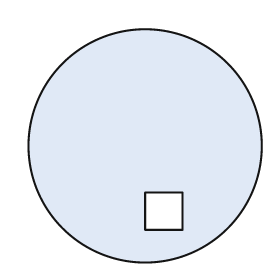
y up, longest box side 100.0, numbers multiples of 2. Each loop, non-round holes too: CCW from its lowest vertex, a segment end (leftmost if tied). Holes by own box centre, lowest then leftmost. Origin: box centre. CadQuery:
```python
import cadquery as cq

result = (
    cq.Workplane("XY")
    .moveTo(0.0, 0.0)
    .circle(50.0)
    .moveTo(0.0, -36.0)
    .lineTo(16.0, -36.0)
    .lineTo(16.0, -20.0)
    .lineTo(0.0, -20.0)
    .close()
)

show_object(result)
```